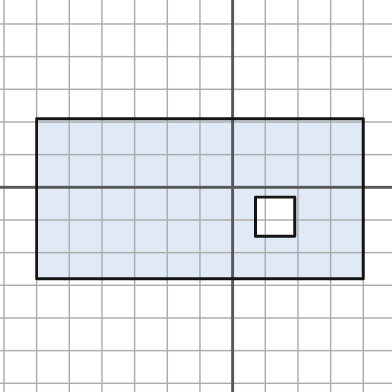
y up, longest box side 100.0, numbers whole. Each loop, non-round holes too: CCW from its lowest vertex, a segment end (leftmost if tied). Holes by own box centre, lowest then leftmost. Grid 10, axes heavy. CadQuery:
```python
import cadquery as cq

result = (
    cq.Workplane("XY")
    .moveTo(-60.0, -28.0)
    .lineTo(40.0, -28.0)
    .lineTo(40.0, 21.0)
    .lineTo(-60.0, 21.0)
    .close()
    .moveTo(7.0, -15.0)
    .lineTo(19.0, -15.0)
    .lineTo(19.0, -3.0)
    .lineTo(7.0, -3.0)
    .close()
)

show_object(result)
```